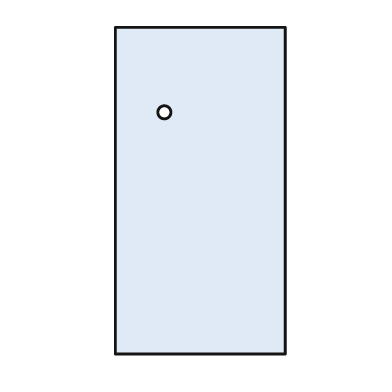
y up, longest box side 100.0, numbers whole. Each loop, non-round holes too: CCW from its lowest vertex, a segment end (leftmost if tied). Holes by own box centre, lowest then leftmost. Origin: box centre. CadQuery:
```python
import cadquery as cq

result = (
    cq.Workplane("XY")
    .moveTo(-26.0, -50.0)
    .lineTo(26.0, -50.0)
    .lineTo(26.0, 50.0)
    .lineTo(-26.0, 50.0)
    .close()
    .moveTo(-11.0, 24.0)
    .circle(2.0)
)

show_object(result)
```